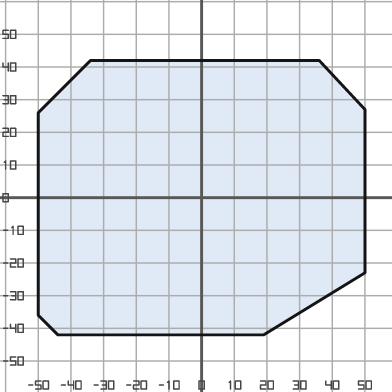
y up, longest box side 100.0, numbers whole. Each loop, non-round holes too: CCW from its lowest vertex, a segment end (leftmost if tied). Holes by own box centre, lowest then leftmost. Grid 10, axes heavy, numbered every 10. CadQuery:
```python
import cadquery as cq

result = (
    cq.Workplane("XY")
    .moveTo(-44.0, -42.0)
    .lineTo(19.0, -42.0)
    .lineTo(50.0, -23.0)
    .lineTo(50.0, 27.0)
    .lineTo(36.0, 42.0)
    .lineTo(-34.0, 42.0)
    .lineTo(-50.0, 26.0)
    .lineTo(-50.0, -36.0)
    .close()
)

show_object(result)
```